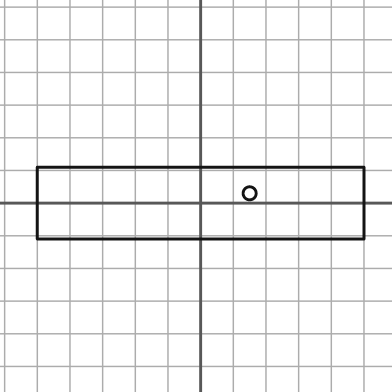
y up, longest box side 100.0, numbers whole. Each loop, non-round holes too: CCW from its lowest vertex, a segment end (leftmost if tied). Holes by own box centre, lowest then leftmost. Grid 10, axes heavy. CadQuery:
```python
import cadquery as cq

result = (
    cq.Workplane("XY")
    .moveTo(-50.0, -11.0)
    .lineTo(50.0, -11.0)
    .lineTo(50.0, 11.0)
    .lineTo(-50.0, 11.0)
    .close()
    .moveTo(15.0, 3.0)
    .circle(2.0)
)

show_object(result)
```